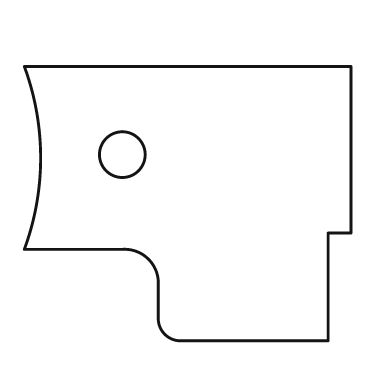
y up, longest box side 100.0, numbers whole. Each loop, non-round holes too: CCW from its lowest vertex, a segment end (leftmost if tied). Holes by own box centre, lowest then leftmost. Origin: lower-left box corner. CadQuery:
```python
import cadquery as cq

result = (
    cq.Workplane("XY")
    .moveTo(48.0, 0.0)
    .lineTo(93.0, 0.0)
    .lineTo(93.0, 33.0)
    .lineTo(100.0, 33.0)
    .lineTo(100.0, 84.0)
    .lineTo(0.0, 84.0)
    .threePointArc((5.0, 56.0), (0.0, 28.0))
    .lineTo(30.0, 28.0)
    .threePointArc((38.0, 25.0), (41.0, 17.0))
    .lineTo(41.0, 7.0)
    .threePointArc((43.0, 2.0), (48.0, 0.0))
    .close()
    .moveTo(30.0, 57.0)
    .circle(7.0)
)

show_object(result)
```